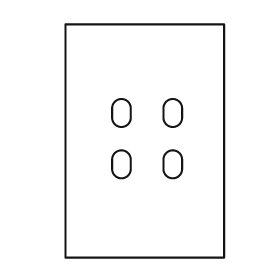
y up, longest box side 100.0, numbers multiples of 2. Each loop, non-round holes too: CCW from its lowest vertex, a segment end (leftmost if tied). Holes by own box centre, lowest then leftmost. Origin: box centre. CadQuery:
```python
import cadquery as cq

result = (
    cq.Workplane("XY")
    .moveTo(-34.0, -50.0)
    .lineTo(34.0, -50.0)
    .lineTo(34.0, 50.0)
    .lineTo(-34.0, 50.0)
    .close()
    .moveTo(-14.0, -12.0)
    .threePointArc((-10.0, -16.0), (-6.0, -12.0))
    .lineTo(-6.0, -8.0)
    .threePointArc((-10.0, -4.0), (-14.0, -8.0))
    .close()
    .moveTo(8.0, -12.0)
    .threePointArc((12.0, -16.0), (16.0, -12.0))
    .lineTo(16.0, -8.0)
    .threePointArc((12.0, -4.0), (8.0, -8.0))
    .close()
    .moveTo(-14.0, 10.0)
    .threePointArc((-10.0, 6.0), (-6.0, 10.0))
    .lineTo(-6.0, 14.0)
    .threePointArc((-10.0, 18.0), (-14.0, 14.0))
    .close()
    .moveTo(8.0, 10.0)
    .threePointArc((12.0, 6.0), (16.0, 10.0))
    .lineTo(16.0, 14.0)
    .threePointArc((12.0, 18.0), (8.0, 14.0))
    .close()
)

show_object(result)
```